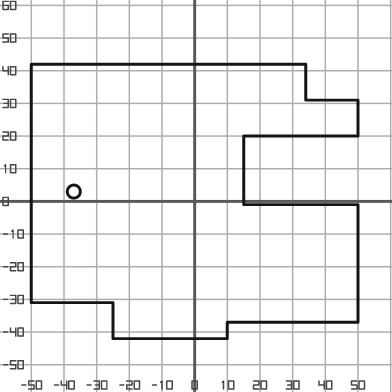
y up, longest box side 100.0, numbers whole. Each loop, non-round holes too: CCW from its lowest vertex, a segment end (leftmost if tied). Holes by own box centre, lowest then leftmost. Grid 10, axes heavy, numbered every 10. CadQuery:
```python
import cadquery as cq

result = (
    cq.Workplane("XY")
    .moveTo(-25.0, -42.0)
    .lineTo(10.0, -42.0)
    .lineTo(10.0, -37.0)
    .lineTo(50.0, -37.0)
    .lineTo(50.0, -1.0)
    .lineTo(15.0, -1.0)
    .lineTo(15.0, 20.0)
    .lineTo(50.0, 20.0)
    .lineTo(50.0, 31.0)
    .lineTo(34.0, 31.0)
    .lineTo(34.0, 42.0)
    .lineTo(-50.0, 42.0)
    .lineTo(-50.0, -31.0)
    .lineTo(-25.0, -31.0)
    .close()
    .moveTo(-37.0, 3.0)
    .circle(2.0)
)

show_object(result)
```